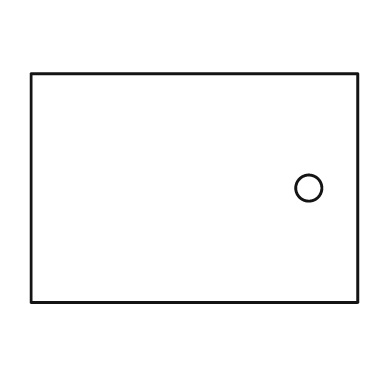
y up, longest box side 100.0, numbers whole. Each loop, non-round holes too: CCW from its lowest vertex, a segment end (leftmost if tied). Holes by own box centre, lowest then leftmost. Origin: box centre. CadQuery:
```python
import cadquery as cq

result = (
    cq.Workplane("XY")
    .moveTo(-50.0, -35.0)
    .lineTo(50.0, -35.0)
    .lineTo(50.0, 35.0)
    .lineTo(-50.0, 35.0)
    .close()
    .moveTo(35.0, 0.0)
    .circle(4.0)
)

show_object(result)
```